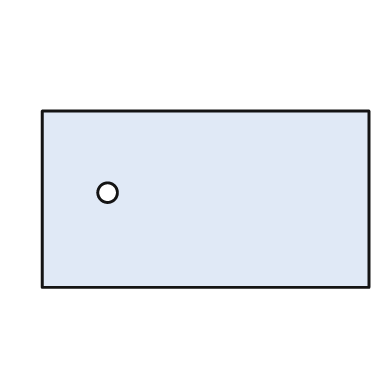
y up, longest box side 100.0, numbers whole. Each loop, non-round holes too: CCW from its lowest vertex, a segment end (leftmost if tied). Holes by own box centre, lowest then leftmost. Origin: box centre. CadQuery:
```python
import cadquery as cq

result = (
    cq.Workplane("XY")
    .moveTo(-50.0, -27.0)
    .lineTo(50.0, -27.0)
    .lineTo(50.0, 27.0)
    .lineTo(-50.0, 27.0)
    .close()
    .moveTo(-30.0, 2.0)
    .circle(3.0)
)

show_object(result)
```